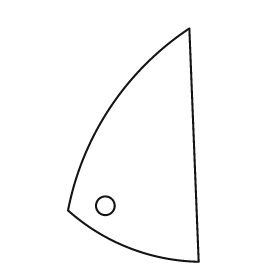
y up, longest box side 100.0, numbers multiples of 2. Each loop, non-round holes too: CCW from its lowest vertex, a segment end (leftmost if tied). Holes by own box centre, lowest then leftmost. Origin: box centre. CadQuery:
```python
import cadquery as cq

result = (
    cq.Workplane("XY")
    .moveTo(28.0, -50.0)
    .lineTo(24.0, 50.0)
    .threePointArc((-10.0, 16.0), (-28.0, -28.0))
    .threePointArc((-2.0, -44.0), (28.0, -50.0))
    .close()
    .moveTo(-12.0, -26.0)
    .circle(4.0)
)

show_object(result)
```